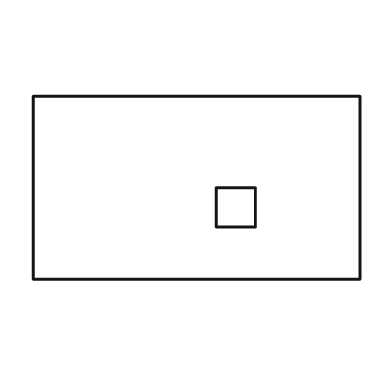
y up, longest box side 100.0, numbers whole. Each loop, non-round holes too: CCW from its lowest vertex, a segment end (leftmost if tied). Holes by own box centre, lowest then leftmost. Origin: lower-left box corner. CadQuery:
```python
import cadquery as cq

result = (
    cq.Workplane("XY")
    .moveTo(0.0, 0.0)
    .lineTo(100.0, 0.0)
    .lineTo(100.0, 56.0)
    .lineTo(0.0, 56.0)
    .close()
    .moveTo(56.0, 16.0)
    .lineTo(68.0, 16.0)
    .lineTo(68.0, 28.0)
    .lineTo(56.0, 28.0)
    .close()
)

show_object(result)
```